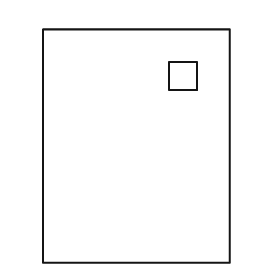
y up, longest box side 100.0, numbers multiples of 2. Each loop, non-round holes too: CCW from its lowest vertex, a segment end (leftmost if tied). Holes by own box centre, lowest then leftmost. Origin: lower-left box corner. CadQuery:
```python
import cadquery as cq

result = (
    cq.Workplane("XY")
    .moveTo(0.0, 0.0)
    .lineTo(80.0, 0.0)
    .lineTo(80.0, 100.0)
    .lineTo(0.0, 100.0)
    .close()
    .moveTo(54.0, 74.0)
    .lineTo(66.0, 74.0)
    .lineTo(66.0, 86.0)
    .lineTo(54.0, 86.0)
    .close()
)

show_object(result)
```